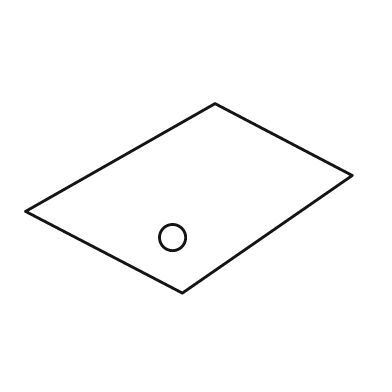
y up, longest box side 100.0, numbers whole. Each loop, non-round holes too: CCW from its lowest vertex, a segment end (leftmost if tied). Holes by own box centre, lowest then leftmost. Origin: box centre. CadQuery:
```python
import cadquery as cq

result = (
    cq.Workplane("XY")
    .moveTo(-2.0, -29.0)
    .lineTo(50.0, 7.0)
    .lineTo(8.0, 29.0)
    .lineTo(-50.0, -4.0)
    .close()
    .moveTo(-5.0, -12.0)
    .circle(4.0)
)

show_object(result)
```